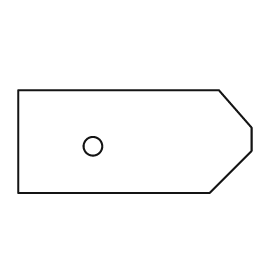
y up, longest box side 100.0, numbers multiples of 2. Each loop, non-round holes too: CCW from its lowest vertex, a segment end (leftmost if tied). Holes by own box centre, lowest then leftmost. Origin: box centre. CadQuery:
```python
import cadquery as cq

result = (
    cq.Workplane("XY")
    .moveTo(-50.0, -22.0)
    .lineTo(32.0, -22.0)
    .lineTo(50.0, -4.0)
    .lineTo(50.0, 6.0)
    .lineTo(36.0, 22.0)
    .lineTo(-50.0, 22.0)
    .close()
    .moveTo(-18.0, -2.0)
    .circle(4.0)
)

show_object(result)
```